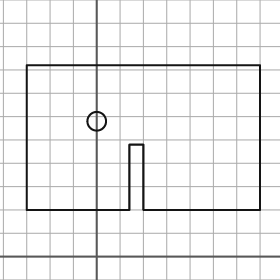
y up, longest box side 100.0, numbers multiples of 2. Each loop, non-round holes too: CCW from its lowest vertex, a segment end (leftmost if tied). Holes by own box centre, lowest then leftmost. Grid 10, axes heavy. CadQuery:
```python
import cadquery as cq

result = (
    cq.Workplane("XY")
    .moveTo(-30.0, 20.0)
    .lineTo(14.0, 20.0)
    .lineTo(14.0, 48.0)
    .lineTo(20.0, 48.0)
    .lineTo(20.0, 20.0)
    .lineTo(70.0, 20.0)
    .lineTo(70.0, 82.0)
    .lineTo(-30.0, 82.0)
    .close()
    .moveTo(0.0, 58.0)
    .circle(4.0)
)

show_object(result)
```